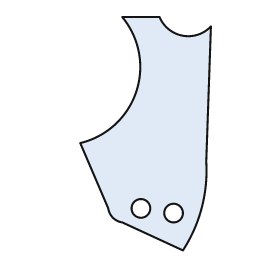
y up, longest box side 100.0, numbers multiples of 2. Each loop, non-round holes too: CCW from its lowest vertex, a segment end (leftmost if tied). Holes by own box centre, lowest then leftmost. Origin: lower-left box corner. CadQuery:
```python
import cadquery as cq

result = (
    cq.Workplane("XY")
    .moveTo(44.0, 0.0)
    .threePointArc((52.0, 18.0), (54.0, 38.0))
    .lineTo(56.0, 96.0)
    .threePointArc((44.0, 92.0), (34.0, 100.0))
    .lineTo(18.0, 100.0)
    .threePointArc((24.0, 68.0), (0.0, 46.0))
    .lineTo(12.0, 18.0)
    .threePointArc((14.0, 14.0), (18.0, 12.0))
    .close()
    .moveTo(40.0, 16.0)
    .circle(4.0)
    .moveTo(26.0, 18.0)
    .circle(4.0)
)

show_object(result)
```